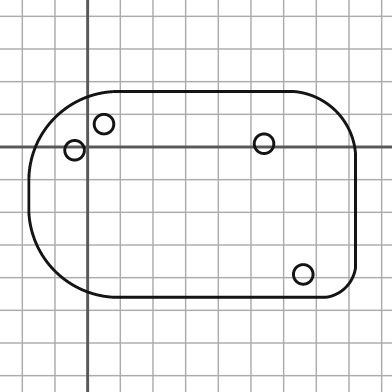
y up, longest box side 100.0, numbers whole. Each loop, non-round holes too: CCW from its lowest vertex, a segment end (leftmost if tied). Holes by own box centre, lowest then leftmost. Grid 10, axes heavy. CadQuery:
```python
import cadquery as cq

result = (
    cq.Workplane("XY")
    .moveTo(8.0, -46.0)
    .lineTo(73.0, -46.0)
    .threePointArc((79.0, -43.0), (82.0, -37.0))
    .lineTo(82.0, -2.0)
    .threePointArc((76.0, 11.0), (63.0, 17.0))
    .lineTo(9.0, 17.0)
    .threePointArc((-10.0, 9.0), (-18.0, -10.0))
    .lineTo(-18.0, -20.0)
    .threePointArc((-10.0, -38.0), (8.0, -46.0))
    .close()
    .moveTo(66.0, -39.0)
    .circle(3.0)
    .moveTo(-4.0, -1.0)
    .circle(3.0)
    .moveTo(54.0, 1.0)
    .circle(3.0)
    .moveTo(5.0, 7.0)
    .circle(3.0)
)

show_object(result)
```